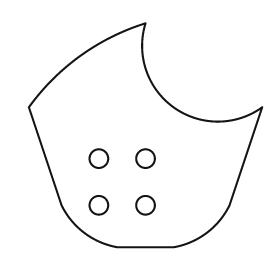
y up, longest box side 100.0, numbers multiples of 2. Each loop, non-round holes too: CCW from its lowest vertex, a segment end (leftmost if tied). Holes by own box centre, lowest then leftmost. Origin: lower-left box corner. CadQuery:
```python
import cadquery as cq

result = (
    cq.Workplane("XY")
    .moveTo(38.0, 0.0)
    .lineTo(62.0, 0.0)
    .threePointArc((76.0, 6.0), (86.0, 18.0))
    .lineTo(100.0, 60.0)
    .threePointArc((62.0, 60.0), (50.0, 96.0))
    .threePointArc((22.0, 82.0), (0.0, 60.0))
    .lineTo(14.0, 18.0)
    .threePointArc((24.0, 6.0), (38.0, 0.0))
    .close()
    .moveTo(30.0, 18.0)
    .circle(4.0)
    .moveTo(50.0, 18.0)
    .circle(4.0)
    .moveTo(30.0, 38.0)
    .circle(4.0)
    .moveTo(50.0, 38.0)
    .circle(4.0)
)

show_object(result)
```